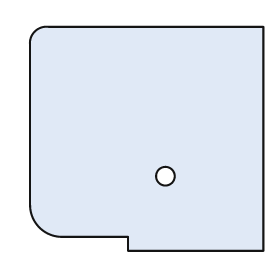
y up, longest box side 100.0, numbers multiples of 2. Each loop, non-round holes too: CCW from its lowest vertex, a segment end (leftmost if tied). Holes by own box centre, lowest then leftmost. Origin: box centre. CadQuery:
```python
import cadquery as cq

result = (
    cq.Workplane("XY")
    .moveTo(-8.0, -48.0)
    .lineTo(50.0, -48.0)
    .lineTo(50.0, 48.0)
    .lineTo(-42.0, 48.0)
    .threePointArc((-48.0, 46.0), (-50.0, 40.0))
    .lineTo(-50.0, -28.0)
    .threePointArc((-46.0, -38.0), (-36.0, -42.0))
    .lineTo(-8.0, -42.0)
    .close()
    .moveTo(8.0, -16.0)
    .circle(4.0)
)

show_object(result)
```